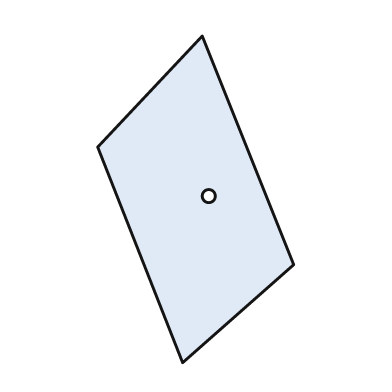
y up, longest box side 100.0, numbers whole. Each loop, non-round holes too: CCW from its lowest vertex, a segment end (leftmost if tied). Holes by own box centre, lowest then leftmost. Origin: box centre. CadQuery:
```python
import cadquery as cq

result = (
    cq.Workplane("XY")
    .moveTo(-4.0, -50.0)
    .lineTo(30.0, -20.0)
    .lineTo(2.0, 50.0)
    .lineTo(-30.0, 16.0)
    .close()
    .moveTo(4.0, 1.0)
    .circle(2.0)
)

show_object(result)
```